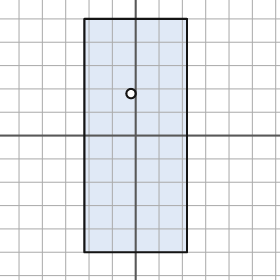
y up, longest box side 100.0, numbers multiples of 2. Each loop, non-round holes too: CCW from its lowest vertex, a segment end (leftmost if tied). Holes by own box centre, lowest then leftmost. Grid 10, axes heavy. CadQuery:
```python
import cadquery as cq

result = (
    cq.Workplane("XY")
    .moveTo(-22.0, -50.0)
    .lineTo(22.0, -50.0)
    .lineTo(22.0, 50.0)
    .lineTo(-22.0, 50.0)
    .close()
    .moveTo(-2.0, 18.0)
    .circle(2.0)
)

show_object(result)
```